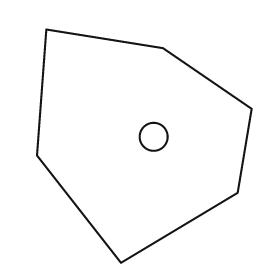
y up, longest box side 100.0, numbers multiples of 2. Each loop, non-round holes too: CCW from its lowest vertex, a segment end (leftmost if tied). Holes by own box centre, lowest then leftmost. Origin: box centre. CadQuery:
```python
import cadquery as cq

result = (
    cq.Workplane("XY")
    .moveTo(-10.0, -50.0)
    .lineTo(40.0, -20.0)
    .lineTo(46.0, 16.0)
    .lineTo(8.0, 42.0)
    .lineTo(-42.0, 50.0)
    .lineTo(-46.0, -4.0)
    .close()
    .moveTo(4.0, 4.0)
    .circle(6.0)
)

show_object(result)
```